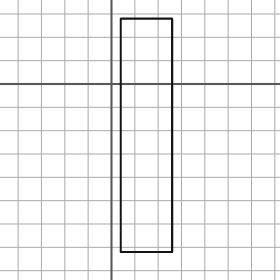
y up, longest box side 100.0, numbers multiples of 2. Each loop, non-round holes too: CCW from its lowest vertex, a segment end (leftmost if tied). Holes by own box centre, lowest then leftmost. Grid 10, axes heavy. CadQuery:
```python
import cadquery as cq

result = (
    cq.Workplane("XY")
    .moveTo(4.0, -72.0)
    .lineTo(26.0, -72.0)
    .lineTo(26.0, 28.0)
    .lineTo(4.0, 28.0)
    .close()
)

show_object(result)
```